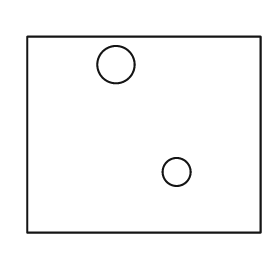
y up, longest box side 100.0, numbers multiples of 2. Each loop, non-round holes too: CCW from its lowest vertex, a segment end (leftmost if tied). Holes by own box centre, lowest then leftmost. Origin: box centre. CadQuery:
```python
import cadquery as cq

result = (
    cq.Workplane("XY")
    .moveTo(-50.0, -42.0)
    .lineTo(50.0, -42.0)
    .lineTo(50.0, 42.0)
    .lineTo(-50.0, 42.0)
    .close()
    .moveTo(14.0, -16.0)
    .circle(6.0)
    .moveTo(-12.0, 30.0)
    .circle(8.0)
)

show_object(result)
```